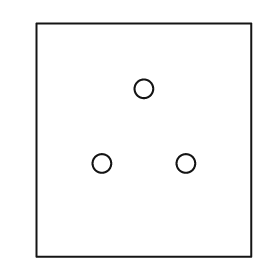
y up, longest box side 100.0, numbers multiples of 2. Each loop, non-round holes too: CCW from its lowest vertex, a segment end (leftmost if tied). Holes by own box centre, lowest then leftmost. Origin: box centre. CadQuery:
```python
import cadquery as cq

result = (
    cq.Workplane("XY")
    .moveTo(-46.0, -50.0)
    .lineTo(46.0, -50.0)
    .lineTo(46.0, 50.0)
    .lineTo(-46.0, 50.0)
    .close()
    .moveTo(-18.0, -10.0)
    .circle(4.0)
    .moveTo(18.0, -10.0)
    .circle(4.0)
    .moveTo(0.0, 22.0)
    .circle(4.0)
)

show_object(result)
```